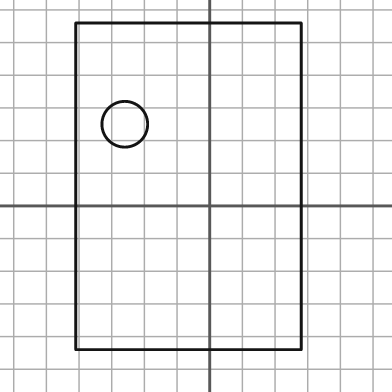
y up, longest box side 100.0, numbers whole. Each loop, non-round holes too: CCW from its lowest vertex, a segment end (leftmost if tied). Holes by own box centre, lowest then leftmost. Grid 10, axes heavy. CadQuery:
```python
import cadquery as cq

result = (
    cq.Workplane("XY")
    .moveTo(-41.0, -44.0)
    .lineTo(28.0, -44.0)
    .lineTo(28.0, 56.0)
    .lineTo(-41.0, 56.0)
    .close()
    .moveTo(-26.0, 25.0)
    .circle(7.0)
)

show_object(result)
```